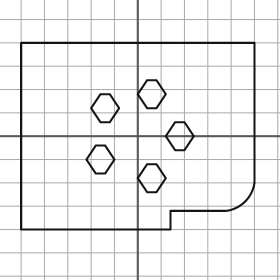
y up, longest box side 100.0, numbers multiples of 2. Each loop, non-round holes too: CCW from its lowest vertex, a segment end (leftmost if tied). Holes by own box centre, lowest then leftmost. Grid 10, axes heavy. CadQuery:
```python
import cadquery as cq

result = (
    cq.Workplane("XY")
    .moveTo(-50.0, -40.0)
    .lineTo(14.0, -40.0)
    .lineTo(14.0, -32.0)
    .lineTo(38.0, -32.0)
    .threePointArc((46.0, -28.0), (50.0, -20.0))
    .lineTo(50.0, 40.0)
    .lineTo(-50.0, 40.0)
    .close()
    .moveTo(4.0, -24.0)
    .lineTo(8.0, -24.0)
    .lineTo(12.0, -18.0)
    .lineTo(8.0, -12.0)
    .lineTo(4.0, -12.0)
    .lineTo(0.0, -18.0)
    .close()
    .moveTo(-18.0, -16.0)
    .lineTo(-14.0, -16.0)
    .lineTo(-10.0, -10.0)
    .lineTo(-14.0, -4.0)
    .lineTo(-18.0, -4.0)
    .lineTo(-22.0, -10.0)
    .close()
    .moveTo(16.0, -6.0)
    .lineTo(20.0, -6.0)
    .lineTo(24.0, 0.0)
    .lineTo(20.0, 6.0)
    .lineTo(16.0, 6.0)
    .lineTo(12.0, 0.0)
    .close()
    .moveTo(-16.0, 6.0)
    .lineTo(-12.0, 6.0)
    .lineTo(-8.0, 12.0)
    .lineTo(-12.0, 18.0)
    .lineTo(-16.0, 18.0)
    .lineTo(-20.0, 12.0)
    .close()
    .moveTo(4.0, 12.0)
    .lineTo(8.0, 12.0)
    .lineTo(12.0, 18.0)
    .lineTo(8.0, 24.0)
    .lineTo(4.0, 24.0)
    .lineTo(0.0, 18.0)
    .close()
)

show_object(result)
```